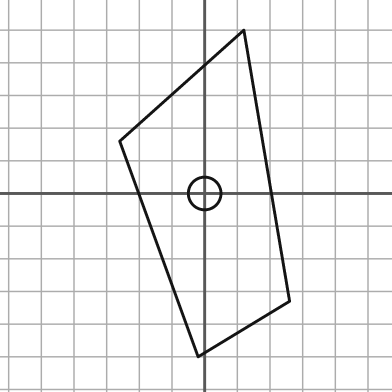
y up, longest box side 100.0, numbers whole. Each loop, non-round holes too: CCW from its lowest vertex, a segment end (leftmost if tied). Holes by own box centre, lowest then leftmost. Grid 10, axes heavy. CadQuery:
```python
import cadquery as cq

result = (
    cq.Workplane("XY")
    .moveTo(-2.0, -50.0)
    .lineTo(26.0, -33.0)
    .lineTo(12.0, 50.0)
    .lineTo(-26.0, 16.0)
    .close()
    .moveTo(0.0, 0.0)
    .circle(5.0)
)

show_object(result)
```